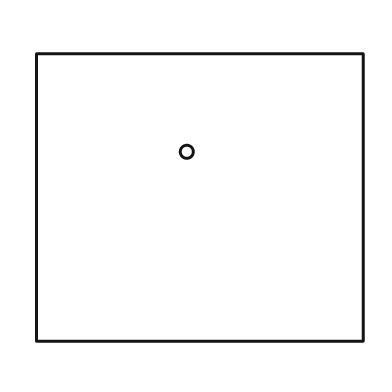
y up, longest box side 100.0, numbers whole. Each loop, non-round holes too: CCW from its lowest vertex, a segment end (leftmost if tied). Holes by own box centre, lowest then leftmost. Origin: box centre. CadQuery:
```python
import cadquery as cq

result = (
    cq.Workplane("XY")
    .moveTo(-50.0, -44.0)
    .lineTo(50.0, -44.0)
    .lineTo(50.0, 44.0)
    .lineTo(-50.0, 44.0)
    .close()
    .moveTo(-4.0, 14.0)
    .circle(2.0)
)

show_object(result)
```